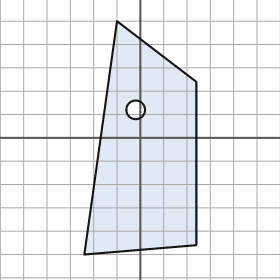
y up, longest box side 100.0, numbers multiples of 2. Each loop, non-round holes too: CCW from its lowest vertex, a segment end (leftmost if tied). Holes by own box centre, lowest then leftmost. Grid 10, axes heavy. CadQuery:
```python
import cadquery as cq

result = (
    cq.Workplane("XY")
    .moveTo(-24.0, -50.0)
    .lineTo(24.0, -46.0)
    .lineTo(24.0, 24.0)
    .lineTo(-10.0, 50.0)
    .close()
    .moveTo(-2.0, 12.0)
    .circle(4.0)
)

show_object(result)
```